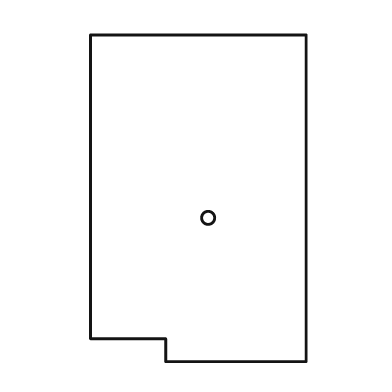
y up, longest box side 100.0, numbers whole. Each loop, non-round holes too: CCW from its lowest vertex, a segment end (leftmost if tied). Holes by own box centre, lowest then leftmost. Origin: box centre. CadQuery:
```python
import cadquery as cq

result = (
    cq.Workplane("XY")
    .moveTo(-10.0, -50.0)
    .lineTo(33.0, -50.0)
    .lineTo(33.0, 50.0)
    .lineTo(-33.0, 50.0)
    .lineTo(-33.0, -43.0)
    .lineTo(-10.0, -43.0)
    .close()
    .moveTo(3.0, -6.0)
    .circle(2.0)
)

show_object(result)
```